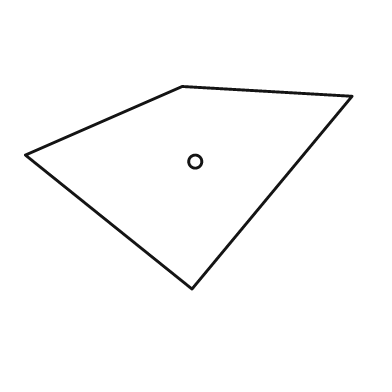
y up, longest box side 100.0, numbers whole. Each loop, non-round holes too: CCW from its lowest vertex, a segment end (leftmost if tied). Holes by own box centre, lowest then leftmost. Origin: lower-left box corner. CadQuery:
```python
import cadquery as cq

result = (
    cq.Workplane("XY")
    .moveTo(51.0, 0.0)
    .lineTo(100.0, 59.0)
    .lineTo(48.0, 62.0)
    .lineTo(0.0, 41.0)
    .close()
    .moveTo(52.0, 39.0)
    .circle(2.0)
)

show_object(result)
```